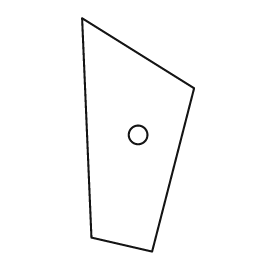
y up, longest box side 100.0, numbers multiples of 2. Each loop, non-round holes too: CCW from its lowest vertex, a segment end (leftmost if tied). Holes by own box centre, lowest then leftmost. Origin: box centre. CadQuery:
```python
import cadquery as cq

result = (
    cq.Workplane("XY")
    .moveTo(6.0, -50.0)
    .lineTo(24.0, 20.0)
    .lineTo(-24.0, 50.0)
    .lineTo(-20.0, -44.0)
    .close()
    .moveTo(0.0, 0.0)
    .circle(4.0)
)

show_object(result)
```